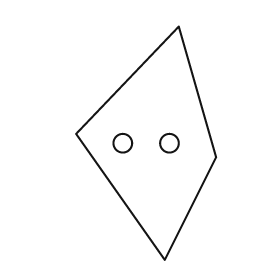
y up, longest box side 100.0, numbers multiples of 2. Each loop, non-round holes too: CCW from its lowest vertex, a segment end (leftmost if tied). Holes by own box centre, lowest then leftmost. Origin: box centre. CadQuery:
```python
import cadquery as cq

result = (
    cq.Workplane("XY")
    .moveTo(8.0, -50.0)
    .lineTo(30.0, -6.0)
    .lineTo(14.0, 50.0)
    .lineTo(-30.0, 4.0)
    .close()
    .moveTo(-10.0, 0.0)
    .circle(4.0)
    .moveTo(10.0, 0.0)
    .circle(4.0)
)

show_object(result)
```